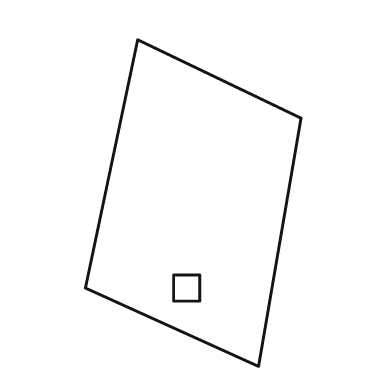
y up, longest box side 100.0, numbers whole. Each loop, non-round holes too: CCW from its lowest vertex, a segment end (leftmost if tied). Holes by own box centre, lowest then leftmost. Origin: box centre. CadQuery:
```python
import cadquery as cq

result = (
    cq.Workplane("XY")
    .moveTo(20.0, -50.0)
    .lineTo(33.0, 26.0)
    .lineTo(-17.0, 50.0)
    .lineTo(-33.0, -26.0)
    .close()
    .moveTo(-6.0, -30.0)
    .lineTo(2.0, -30.0)
    .lineTo(2.0, -22.0)
    .lineTo(-6.0, -22.0)
    .close()
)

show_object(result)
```